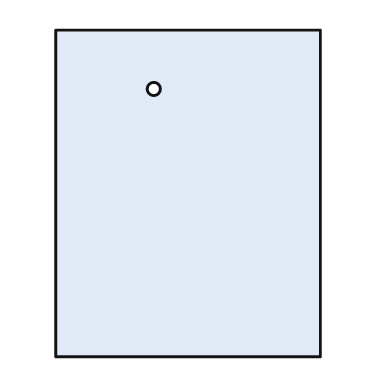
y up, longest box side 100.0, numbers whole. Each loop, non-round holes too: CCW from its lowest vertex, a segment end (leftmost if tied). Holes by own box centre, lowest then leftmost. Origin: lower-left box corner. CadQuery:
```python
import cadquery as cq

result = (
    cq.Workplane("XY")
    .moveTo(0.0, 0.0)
    .lineTo(81.0, 0.0)
    .lineTo(81.0, 100.0)
    .lineTo(0.0, 100.0)
    .close()
    .moveTo(30.0, 82.0)
    .circle(2.0)
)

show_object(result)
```